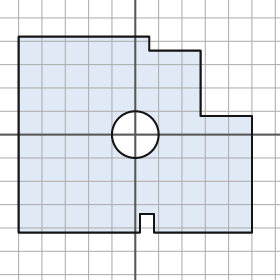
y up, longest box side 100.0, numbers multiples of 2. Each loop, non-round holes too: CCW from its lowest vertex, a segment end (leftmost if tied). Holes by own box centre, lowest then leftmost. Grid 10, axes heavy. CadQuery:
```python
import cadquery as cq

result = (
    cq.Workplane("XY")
    .moveTo(-50.0, -42.0)
    .lineTo(2.0, -42.0)
    .lineTo(2.0, -34.0)
    .lineTo(8.0, -34.0)
    .lineTo(8.0, -42.0)
    .lineTo(50.0, -42.0)
    .lineTo(50.0, 8.0)
    .lineTo(28.0, 8.0)
    .lineTo(28.0, 36.0)
    .lineTo(6.0, 36.0)
    .lineTo(6.0, 42.0)
    .lineTo(-50.0, 42.0)
    .close()
    .moveTo(0.0, 0.0)
    .circle(10.0)
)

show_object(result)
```